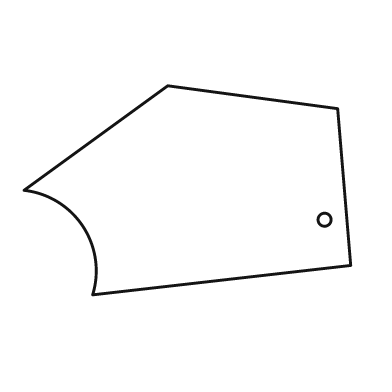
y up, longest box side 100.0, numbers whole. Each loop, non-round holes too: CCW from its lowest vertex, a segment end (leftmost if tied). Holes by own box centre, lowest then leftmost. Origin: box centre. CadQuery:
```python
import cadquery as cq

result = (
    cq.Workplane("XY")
    .moveTo(-29.0, -32.0)
    .lineTo(50.0, -23.0)
    .lineTo(46.0, 25.0)
    .lineTo(-6.0, 32.0)
    .lineTo(-50.0, 0.0)
    .threePointArc((-32.0, -11.0), (-29.0, -32.0))
    .close()
    .moveTo(42.0, -9.0)
    .circle(2.0)
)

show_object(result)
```